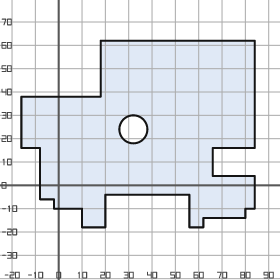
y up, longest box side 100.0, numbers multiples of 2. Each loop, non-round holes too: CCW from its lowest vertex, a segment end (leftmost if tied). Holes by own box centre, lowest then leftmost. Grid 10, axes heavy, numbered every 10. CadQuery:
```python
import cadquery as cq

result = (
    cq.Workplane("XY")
    .moveTo(10.0, -18.0)
    .lineTo(20.0, -18.0)
    .lineTo(20.0, -4.0)
    .lineTo(56.0, -4.0)
    .lineTo(56.0, -18.0)
    .lineTo(62.0, -18.0)
    .lineTo(62.0, -14.0)
    .lineTo(80.0, -14.0)
    .lineTo(80.0, -10.0)
    .lineTo(84.0, -10.0)
    .lineTo(84.0, 4.0)
    .lineTo(66.0, 4.0)
    .lineTo(66.0, 16.0)
    .lineTo(84.0, 16.0)
    .lineTo(84.0, 62.0)
    .lineTo(18.0, 62.0)
    .lineTo(18.0, 38.0)
    .lineTo(-16.0, 38.0)
    .lineTo(-16.0, 16.0)
    .lineTo(-8.0, 16.0)
    .lineTo(-8.0, -6.0)
    .lineTo(-2.0, -6.0)
    .lineTo(-2.0, -10.0)
    .lineTo(10.0, -10.0)
    .close()
    .moveTo(32.0, 24.0)
    .circle(6.0)
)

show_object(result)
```